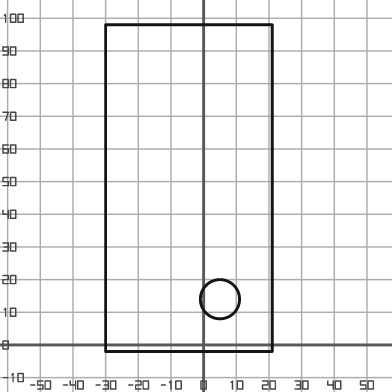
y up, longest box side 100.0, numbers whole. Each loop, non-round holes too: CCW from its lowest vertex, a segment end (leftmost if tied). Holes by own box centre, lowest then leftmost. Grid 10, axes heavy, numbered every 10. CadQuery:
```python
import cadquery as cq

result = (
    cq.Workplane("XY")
    .moveTo(-30.0, -2.0)
    .lineTo(21.0, -2.0)
    .lineTo(21.0, 98.0)
    .lineTo(-30.0, 98.0)
    .close()
    .moveTo(5.0, 14.0)
    .circle(6.0)
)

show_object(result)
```